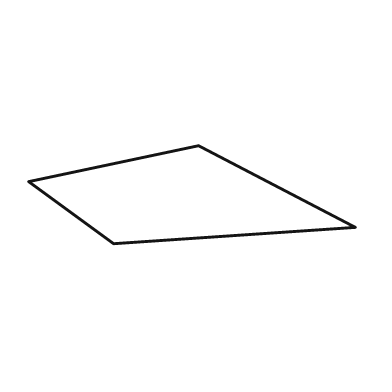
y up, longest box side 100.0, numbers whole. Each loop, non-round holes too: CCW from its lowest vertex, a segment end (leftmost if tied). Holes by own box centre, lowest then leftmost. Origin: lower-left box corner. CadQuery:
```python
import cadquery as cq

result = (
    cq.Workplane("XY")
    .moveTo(26.0, 0.0)
    .lineTo(100.0, 5.0)
    .lineTo(52.0, 30.0)
    .lineTo(0.0, 19.0)
    .close()
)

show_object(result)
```